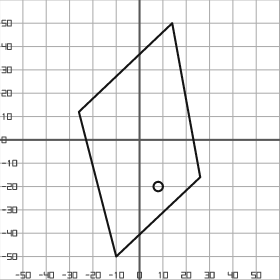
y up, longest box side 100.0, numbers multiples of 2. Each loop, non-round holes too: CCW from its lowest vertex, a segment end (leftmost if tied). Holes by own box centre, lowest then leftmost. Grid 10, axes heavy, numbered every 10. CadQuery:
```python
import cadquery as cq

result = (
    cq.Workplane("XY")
    .moveTo(-10.0, -50.0)
    .lineTo(26.0, -16.0)
    .lineTo(14.0, 50.0)
    .lineTo(-26.0, 12.0)
    .close()
    .moveTo(8.0, -20.0)
    .circle(2.0)
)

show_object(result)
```